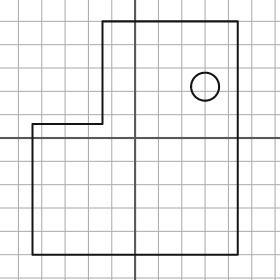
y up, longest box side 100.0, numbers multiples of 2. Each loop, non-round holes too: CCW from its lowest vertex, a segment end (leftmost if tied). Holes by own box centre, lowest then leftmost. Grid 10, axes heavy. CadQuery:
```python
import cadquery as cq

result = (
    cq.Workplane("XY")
    .moveTo(-44.0, -50.0)
    .lineTo(44.0, -50.0)
    .lineTo(44.0, 50.0)
    .lineTo(-14.0, 50.0)
    .lineTo(-14.0, 6.0)
    .lineTo(-44.0, 6.0)
    .close()
    .moveTo(30.0, 22.0)
    .circle(6.0)
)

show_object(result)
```